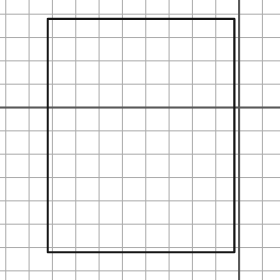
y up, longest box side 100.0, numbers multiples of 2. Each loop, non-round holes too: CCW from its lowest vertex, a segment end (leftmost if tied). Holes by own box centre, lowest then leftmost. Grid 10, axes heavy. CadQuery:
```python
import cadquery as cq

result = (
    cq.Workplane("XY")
    .moveTo(-82.0, -62.0)
    .lineTo(-2.0, -62.0)
    .lineTo(-2.0, 38.0)
    .lineTo(-82.0, 38.0)
    .close()
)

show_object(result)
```